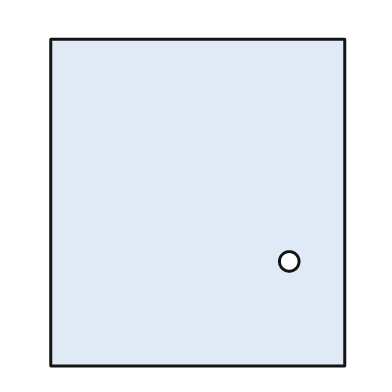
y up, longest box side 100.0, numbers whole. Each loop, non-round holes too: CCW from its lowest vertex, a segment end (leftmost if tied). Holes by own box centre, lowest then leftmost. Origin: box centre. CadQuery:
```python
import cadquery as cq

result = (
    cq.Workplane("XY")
    .moveTo(-45.0, -50.0)
    .lineTo(45.0, -50.0)
    .lineTo(45.0, 50.0)
    .lineTo(-45.0, 50.0)
    .close()
    .moveTo(28.0, -18.0)
    .circle(3.0)
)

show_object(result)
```